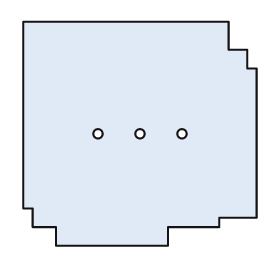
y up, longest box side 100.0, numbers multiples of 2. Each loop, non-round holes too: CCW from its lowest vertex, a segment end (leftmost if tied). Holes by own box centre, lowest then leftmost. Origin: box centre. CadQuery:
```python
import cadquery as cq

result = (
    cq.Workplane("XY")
    .moveTo(-36.0, -48.0)
    .lineTo(12.0, -48.0)
    .lineTo(12.0, -40.0)
    .lineTo(34.0, -40.0)
    .lineTo(34.0, -36.0)
    .lineTo(50.0, -36.0)
    .lineTo(50.0, 28.0)
    .lineTo(46.0, 28.0)
    .lineTo(46.0, 36.0)
    .lineTo(38.0, 36.0)
    .lineTo(38.0, 48.0)
    .lineTo(-50.0, 48.0)
    .lineTo(-50.0, -32.0)
    .lineTo(-46.0, -32.0)
    .lineTo(-46.0, -40.0)
    .lineTo(-36.0, -40.0)
    .close()
    .moveTo(-18.0, 0.0)
    .circle(2.0)
    .moveTo(0.0, 0.0)
    .circle(2.0)
    .moveTo(18.0, 0.0)
    .circle(2.0)
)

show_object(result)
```